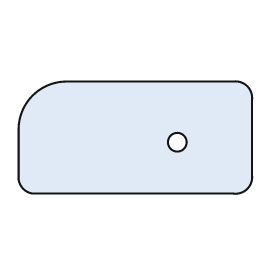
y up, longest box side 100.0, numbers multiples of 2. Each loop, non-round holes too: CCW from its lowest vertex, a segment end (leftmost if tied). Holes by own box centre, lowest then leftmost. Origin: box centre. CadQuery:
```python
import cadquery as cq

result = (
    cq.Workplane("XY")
    .moveTo(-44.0, -24.0)
    .lineTo(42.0, -24.0)
    .threePointArc((48.0, -22.0), (50.0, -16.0))
    .lineTo(50.0, 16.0)
    .threePointArc((48.0, 22.0), (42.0, 24.0))
    .lineTo(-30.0, 24.0)
    .threePointArc((-44.0, 18.0), (-50.0, 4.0))
    .lineTo(-50.0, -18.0)
    .threePointArc((-48.0, -22.0), (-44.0, -24.0))
    .close()
    .moveTo(18.0, -2.0)
    .circle(4.0)
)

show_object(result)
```